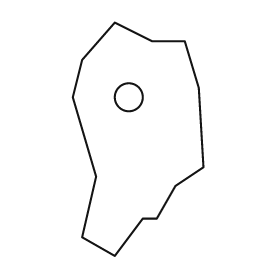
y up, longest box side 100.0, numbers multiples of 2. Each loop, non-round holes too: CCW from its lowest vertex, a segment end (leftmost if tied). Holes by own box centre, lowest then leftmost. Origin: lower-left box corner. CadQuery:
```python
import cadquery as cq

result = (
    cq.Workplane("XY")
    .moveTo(18.0, 0.0)
    .lineTo(30.0, 16.0)
    .lineTo(36.0, 16.0)
    .lineTo(44.0, 30.0)
    .lineTo(56.0, 38.0)
    .lineTo(54.0, 72.0)
    .lineTo(48.0, 92.0)
    .lineTo(34.0, 92.0)
    .lineTo(18.0, 100.0)
    .lineTo(4.0, 84.0)
    .lineTo(0.0, 68.0)
    .lineTo(10.0, 34.0)
    .lineTo(4.0, 8.0)
    .close()
    .moveTo(24.0, 68.0)
    .circle(6.0)
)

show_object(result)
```